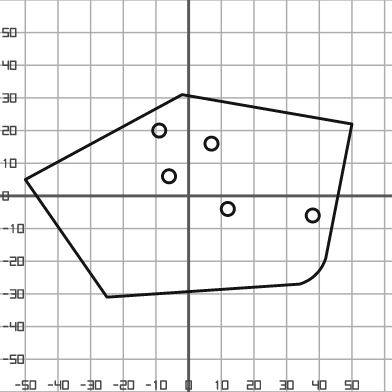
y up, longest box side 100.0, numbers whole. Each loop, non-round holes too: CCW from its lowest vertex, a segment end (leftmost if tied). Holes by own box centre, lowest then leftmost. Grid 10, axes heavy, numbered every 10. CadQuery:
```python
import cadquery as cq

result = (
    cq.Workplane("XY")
    .moveTo(-25.0, -31.0)
    .lineTo(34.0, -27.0)
    .threePointArc((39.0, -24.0), (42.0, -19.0))
    .lineTo(50.0, 22.0)
    .lineTo(-2.0, 31.0)
    .lineTo(-50.0, 5.0)
    .close()
    .moveTo(38.0, -6.0)
    .circle(2.0)
    .moveTo(12.0, -4.0)
    .circle(2.0)
    .moveTo(-6.0, 6.0)
    .circle(2.0)
    .moveTo(7.0, 16.0)
    .circle(2.0)
    .moveTo(-9.0, 20.0)
    .circle(2.0)
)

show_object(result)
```